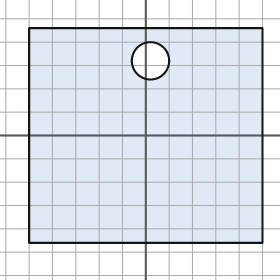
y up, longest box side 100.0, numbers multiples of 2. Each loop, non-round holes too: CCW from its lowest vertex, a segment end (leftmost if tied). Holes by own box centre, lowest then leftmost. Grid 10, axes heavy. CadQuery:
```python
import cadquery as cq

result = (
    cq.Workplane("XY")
    .moveTo(-50.0, -46.0)
    .lineTo(50.0, -46.0)
    .lineTo(50.0, 46.0)
    .lineTo(-50.0, 46.0)
    .close()
    .moveTo(2.0, 32.0)
    .circle(8.0)
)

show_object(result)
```